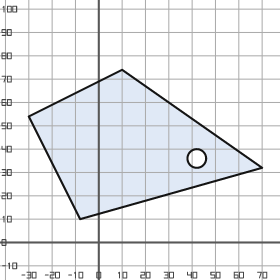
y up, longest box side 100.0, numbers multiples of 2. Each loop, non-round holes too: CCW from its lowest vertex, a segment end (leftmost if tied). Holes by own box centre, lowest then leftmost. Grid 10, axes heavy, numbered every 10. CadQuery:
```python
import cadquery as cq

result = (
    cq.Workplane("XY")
    .moveTo(-8.0, 10.0)
    .lineTo(70.0, 32.0)
    .lineTo(10.0, 74.0)
    .lineTo(-30.0, 54.0)
    .close()
    .moveTo(42.0, 36.0)
    .circle(4.0)
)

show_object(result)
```